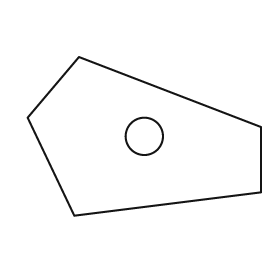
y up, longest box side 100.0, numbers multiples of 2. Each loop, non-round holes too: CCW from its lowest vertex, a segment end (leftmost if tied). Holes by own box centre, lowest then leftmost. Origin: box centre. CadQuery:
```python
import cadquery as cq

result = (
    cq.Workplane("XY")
    .moveTo(-30.0, -34.0)
    .lineTo(50.0, -24.0)
    .lineTo(50.0, 4.0)
    .lineTo(-28.0, 34.0)
    .lineTo(-50.0, 8.0)
    .close()
    .moveTo(0.0, 0.0)
    .circle(8.0)
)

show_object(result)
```